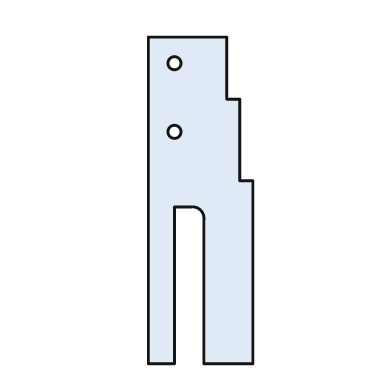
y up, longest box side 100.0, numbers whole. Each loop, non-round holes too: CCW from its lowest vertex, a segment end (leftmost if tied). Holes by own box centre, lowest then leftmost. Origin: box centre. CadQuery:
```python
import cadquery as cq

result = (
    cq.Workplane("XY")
    .moveTo(-16.0, -50.0)
    .lineTo(-8.0, -50.0)
    .lineTo(-8.0, -2.0)
    .lineTo(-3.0, -2.0)
    .threePointArc((0.0, -3.0), (1.0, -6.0))
    .lineTo(1.0, -50.0)
    .lineTo(16.0, -50.0)
    .lineTo(16.0, 6.0)
    .lineTo(12.0, 6.0)
    .lineTo(12.0, 31.0)
    .lineTo(8.0, 31.0)
    .lineTo(8.0, 50.0)
    .lineTo(-16.0, 50.0)
    .close()
    .moveTo(-8.0, 21.0)
    .circle(2.0)
    .moveTo(-8.0, 42.0)
    .circle(2.0)
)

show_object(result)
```